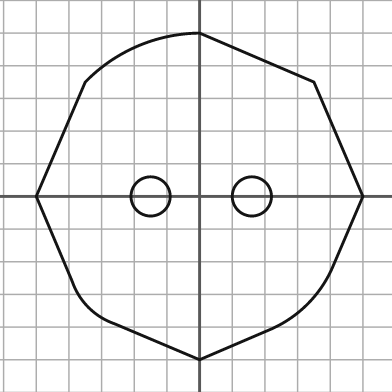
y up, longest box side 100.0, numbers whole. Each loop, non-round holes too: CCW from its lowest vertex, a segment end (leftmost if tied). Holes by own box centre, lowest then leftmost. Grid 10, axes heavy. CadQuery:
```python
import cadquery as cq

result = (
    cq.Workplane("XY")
    .moveTo(0.0, -50.0)
    .lineTo(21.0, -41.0)
    .threePointArc((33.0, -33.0), (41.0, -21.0))
    .lineTo(50.0, 0.0)
    .lineTo(35.0, 35.0)
    .lineTo(0.0, 50.0)
    .threePointArc((-19.0, 46.0), (-35.0, 35.0))
    .lineTo(-50.0, 0.0)
    .lineTo(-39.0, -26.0)
    .threePointArc((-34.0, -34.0), (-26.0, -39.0))
    .close()
    .moveTo(-15.0, 0.0)
    .circle(6.0)
    .moveTo(16.0, 0.0)
    .circle(6.0)
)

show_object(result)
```